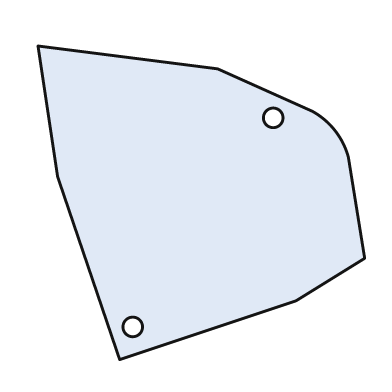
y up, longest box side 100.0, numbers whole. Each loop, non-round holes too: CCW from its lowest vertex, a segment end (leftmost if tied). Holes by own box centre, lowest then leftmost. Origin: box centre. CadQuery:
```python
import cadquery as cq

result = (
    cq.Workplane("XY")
    .moveTo(-25.0, -48.0)
    .lineTo(29.0, -30.0)
    .lineTo(50.0, -17.0)
    .lineTo(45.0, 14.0)
    .threePointArc((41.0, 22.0), (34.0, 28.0))
    .lineTo(5.0, 41.0)
    .lineTo(-50.0, 48.0)
    .lineTo(-44.0, 8.0)
    .close()
    .moveTo(-21.0, -38.0)
    .circle(3.0)
    .moveTo(22.0, 26.0)
    .circle(3.0)
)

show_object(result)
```